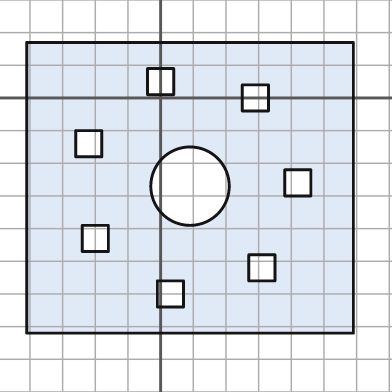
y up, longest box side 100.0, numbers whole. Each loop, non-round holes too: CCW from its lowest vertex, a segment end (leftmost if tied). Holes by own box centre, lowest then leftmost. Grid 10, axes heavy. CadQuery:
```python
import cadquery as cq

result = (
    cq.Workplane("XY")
    .moveTo(-41.0, -72.0)
    .lineTo(59.0, -72.0)
    .lineTo(59.0, 17.0)
    .lineTo(-41.0, 17.0)
    .close()
    .moveTo(-1.0, -64.0)
    .lineTo(7.0, -64.0)
    .lineTo(7.0, -56.0)
    .lineTo(-1.0, -56.0)
    .close()
    .moveTo(27.0, -56.0)
    .lineTo(35.0, -56.0)
    .lineTo(35.0, -48.0)
    .lineTo(27.0, -48.0)
    .close()
    .moveTo(-24.0, -47.0)
    .lineTo(-16.0, -47.0)
    .lineTo(-16.0, -39.0)
    .lineTo(-24.0, -39.0)
    .close()
    .moveTo(9.0, -27.0)
    .circle(12.0)
    .moveTo(38.0, -30.0)
    .lineTo(46.0, -30.0)
    .lineTo(46.0, -22.0)
    .lineTo(38.0, -22.0)
    .close()
    .moveTo(-26.0, -18.0)
    .lineTo(-18.0, -18.0)
    .lineTo(-18.0, -10.0)
    .lineTo(-26.0, -10.0)
    .close()
    .moveTo(25.0, -4.0)
    .lineTo(33.0, -4.0)
    .lineTo(33.0, 4.0)
    .lineTo(25.0, 4.0)
    .close()
    .moveTo(-4.0, 1.0)
    .lineTo(4.0, 1.0)
    .lineTo(4.0, 9.0)
    .lineTo(-4.0, 9.0)
    .close()
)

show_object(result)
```